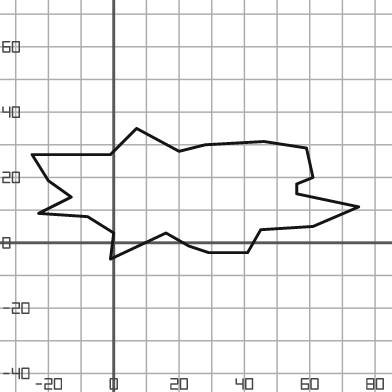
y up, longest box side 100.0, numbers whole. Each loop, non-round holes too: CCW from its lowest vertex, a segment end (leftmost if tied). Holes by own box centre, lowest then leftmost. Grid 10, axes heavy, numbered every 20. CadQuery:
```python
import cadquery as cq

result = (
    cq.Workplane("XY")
    .moveTo(-1.0, -5.0)
    .lineTo(16.0, 3.0)
    .lineTo(23.0, -1.0)
    .lineTo(29.0, -3.0)
    .lineTo(41.0, -3.0)
    .lineTo(45.0, 4.0)
    .lineTo(61.0, 5.0)
    .lineTo(75.0, 11.0)
    .lineTo(56.0, 15.0)
    .lineTo(56.0, 18.0)
    .lineTo(61.0, 20.0)
    .lineTo(59.0, 29.0)
    .lineTo(46.0, 31.0)
    .lineTo(28.0, 30.0)
    .lineTo(20.0, 28.0)
    .lineTo(7.0, 35.0)
    .lineTo(-1.0, 27.0)
    .lineTo(-25.0, 27.0)
    .lineTo(-20.0, 19.0)
    .lineTo(-13.0, 14.0)
    .lineTo(-23.0, 9.0)
    .lineTo(-8.0, 8.0)
    .lineTo(0.0, 3.0)
    .close()
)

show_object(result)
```